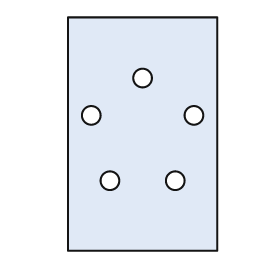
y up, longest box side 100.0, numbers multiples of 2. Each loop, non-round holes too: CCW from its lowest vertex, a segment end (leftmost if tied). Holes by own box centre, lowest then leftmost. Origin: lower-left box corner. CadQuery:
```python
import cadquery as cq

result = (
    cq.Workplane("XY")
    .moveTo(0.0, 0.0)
    .lineTo(64.0, 0.0)
    .lineTo(64.0, 100.0)
    .lineTo(0.0, 100.0)
    .close()
    .moveTo(18.0, 30.0)
    .circle(4.0)
    .moveTo(46.0, 30.0)
    .circle(4.0)
    .moveTo(10.0, 58.0)
    .circle(4.0)
    .moveTo(54.0, 58.0)
    .circle(4.0)
    .moveTo(32.0, 74.0)
    .circle(4.0)
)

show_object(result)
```